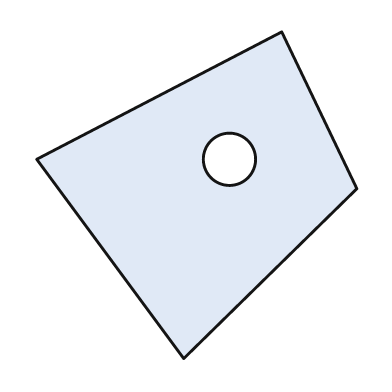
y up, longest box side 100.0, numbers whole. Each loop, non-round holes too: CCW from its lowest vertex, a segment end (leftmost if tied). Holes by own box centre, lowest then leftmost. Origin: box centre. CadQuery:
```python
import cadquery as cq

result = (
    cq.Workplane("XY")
    .moveTo(-4.0, -50.0)
    .lineTo(49.0, 2.0)
    .lineTo(26.0, 50.0)
    .lineTo(-49.0, 11.0)
    .close()
    .moveTo(10.0, 11.0)
    .circle(8.0)
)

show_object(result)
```